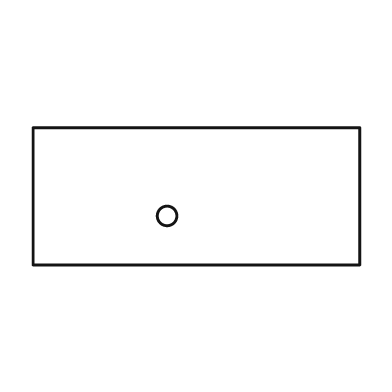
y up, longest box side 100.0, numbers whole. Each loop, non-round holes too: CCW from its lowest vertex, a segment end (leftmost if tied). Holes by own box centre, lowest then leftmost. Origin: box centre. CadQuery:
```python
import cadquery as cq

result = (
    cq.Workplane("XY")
    .moveTo(-50.0, -21.0)
    .lineTo(50.0, -21.0)
    .lineTo(50.0, 21.0)
    .lineTo(-50.0, 21.0)
    .close()
    .moveTo(-9.0, -6.0)
    .circle(3.0)
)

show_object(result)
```